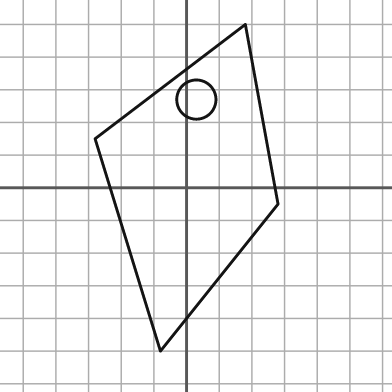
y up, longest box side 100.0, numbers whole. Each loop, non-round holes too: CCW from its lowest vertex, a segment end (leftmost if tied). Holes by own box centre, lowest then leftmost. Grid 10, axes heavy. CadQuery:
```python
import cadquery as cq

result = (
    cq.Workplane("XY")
    .moveTo(-8.0, -50.0)
    .lineTo(28.0, -5.0)
    .lineTo(18.0, 50.0)
    .lineTo(-28.0, 15.0)
    .close()
    .moveTo(3.0, 27.0)
    .circle(6.0)
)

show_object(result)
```